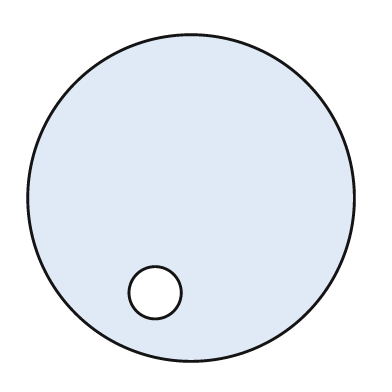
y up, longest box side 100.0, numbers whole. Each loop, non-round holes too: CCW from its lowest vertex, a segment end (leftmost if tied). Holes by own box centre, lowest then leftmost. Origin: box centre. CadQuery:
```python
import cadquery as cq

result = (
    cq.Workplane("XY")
    .moveTo(0.0, 0.0)
    .circle(50.0)
    .moveTo(-11.0, -29.0)
    .circle(8.0)
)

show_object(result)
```